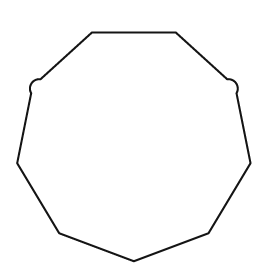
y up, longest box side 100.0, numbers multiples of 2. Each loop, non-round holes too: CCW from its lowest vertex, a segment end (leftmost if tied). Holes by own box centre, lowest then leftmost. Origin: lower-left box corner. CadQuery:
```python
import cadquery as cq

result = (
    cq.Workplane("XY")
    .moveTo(50.0, 0.0)
    .lineTo(82.0, 12.0)
    .lineTo(100.0, 42.0)
    .lineTo(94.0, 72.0)
    .threePointArc((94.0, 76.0), (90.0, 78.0))
    .lineTo(68.0, 98.0)
    .lineTo(32.0, 98.0)
    .lineTo(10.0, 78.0)
    .threePointArc((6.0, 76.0), (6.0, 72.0))
    .lineTo(0.0, 42.0)
    .lineTo(18.0, 12.0)
    .close()
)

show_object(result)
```